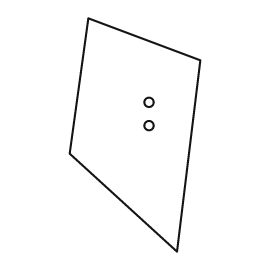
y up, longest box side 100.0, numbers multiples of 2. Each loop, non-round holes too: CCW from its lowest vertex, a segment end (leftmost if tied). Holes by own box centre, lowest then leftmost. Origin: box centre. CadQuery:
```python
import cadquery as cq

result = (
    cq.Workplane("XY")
    .moveTo(18.0, -50.0)
    .lineTo(28.0, 32.0)
    .lineTo(-20.0, 50.0)
    .lineTo(-28.0, -8.0)
    .close()
    .moveTo(6.0, 4.0)
    .circle(2.0)
    .moveTo(6.0, 14.0)
    .circle(2.0)
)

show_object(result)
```